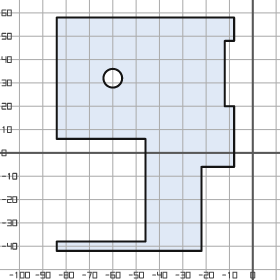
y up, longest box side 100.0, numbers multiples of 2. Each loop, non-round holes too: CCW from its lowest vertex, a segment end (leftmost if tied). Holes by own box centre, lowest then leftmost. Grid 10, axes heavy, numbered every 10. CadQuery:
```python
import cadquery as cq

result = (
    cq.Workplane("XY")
    .moveTo(-84.0, -42.0)
    .lineTo(-22.0, -42.0)
    .lineTo(-22.0, -6.0)
    .lineTo(-8.0, -6.0)
    .lineTo(-8.0, 20.0)
    .lineTo(-12.0, 20.0)
    .lineTo(-12.0, 48.0)
    .lineTo(-8.0, 48.0)
    .lineTo(-8.0, 58.0)
    .lineTo(-84.0, 58.0)
    .lineTo(-84.0, 6.0)
    .lineTo(-46.0, 6.0)
    .lineTo(-46.0, -38.0)
    .lineTo(-84.0, -38.0)
    .close()
    .moveTo(-60.0, 32.0)
    .circle(4.0)
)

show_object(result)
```